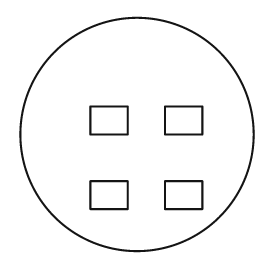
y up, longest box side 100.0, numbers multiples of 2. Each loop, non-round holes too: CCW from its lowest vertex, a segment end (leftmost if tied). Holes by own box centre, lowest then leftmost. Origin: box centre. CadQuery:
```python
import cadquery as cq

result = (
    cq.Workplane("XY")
    .moveTo(0.0, 0.0)
    .circle(50.0)
    .moveTo(-20.0, -32.0)
    .lineTo(-4.0, -32.0)
    .lineTo(-4.0, -20.0)
    .lineTo(-20.0, -20.0)
    .close()
    .moveTo(12.0, -32.0)
    .lineTo(28.0, -32.0)
    .lineTo(28.0, -20.0)
    .lineTo(12.0, -20.0)
    .close()
    .moveTo(-20.0, 0.0)
    .lineTo(-4.0, 0.0)
    .lineTo(-4.0, 12.0)
    .lineTo(-20.0, 12.0)
    .close()
    .moveTo(12.0, 0.0)
    .lineTo(28.0, 0.0)
    .lineTo(28.0, 12.0)
    .lineTo(12.0, 12.0)
    .close()
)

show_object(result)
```